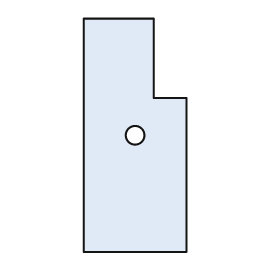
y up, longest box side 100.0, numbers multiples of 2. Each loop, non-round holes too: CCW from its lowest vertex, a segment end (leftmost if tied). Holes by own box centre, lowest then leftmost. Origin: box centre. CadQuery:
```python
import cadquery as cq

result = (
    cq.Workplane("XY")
    .moveTo(-22.0, -50.0)
    .lineTo(22.0, -50.0)
    .lineTo(22.0, 16.0)
    .lineTo(8.0, 16.0)
    .lineTo(8.0, 50.0)
    .lineTo(-22.0, 50.0)
    .close()
    .moveTo(0.0, 0.0)
    .circle(4.0)
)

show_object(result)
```